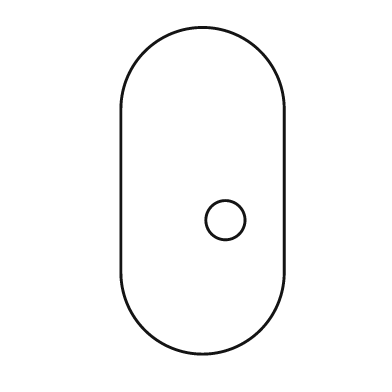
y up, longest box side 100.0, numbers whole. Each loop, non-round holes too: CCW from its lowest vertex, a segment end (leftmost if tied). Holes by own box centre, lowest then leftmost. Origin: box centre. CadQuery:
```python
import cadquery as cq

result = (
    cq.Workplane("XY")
    .moveTo(-25.0, -25.0)
    .threePointArc((0.0, -50.0), (25.0, -25.0))
    .lineTo(25.0, 25.0)
    .threePointArc((0.0, 50.0), (-25.0, 25.0))
    .close()
    .moveTo(7.0, -9.0)
    .circle(6.0)
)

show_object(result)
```